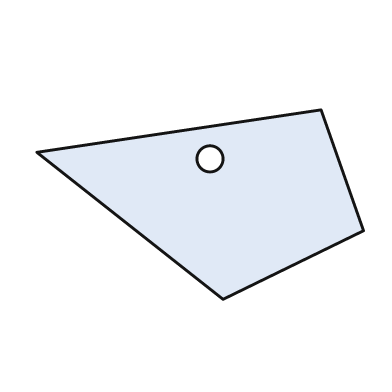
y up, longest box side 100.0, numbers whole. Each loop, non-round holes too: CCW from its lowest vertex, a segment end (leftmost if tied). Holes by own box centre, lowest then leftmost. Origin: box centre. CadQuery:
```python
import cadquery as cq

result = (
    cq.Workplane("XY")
    .moveTo(7.0, -29.0)
    .lineTo(50.0, -8.0)
    .lineTo(37.0, 29.0)
    .lineTo(-50.0, 16.0)
    .close()
    .moveTo(3.0, 14.0)
    .circle(4.0)
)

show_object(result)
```